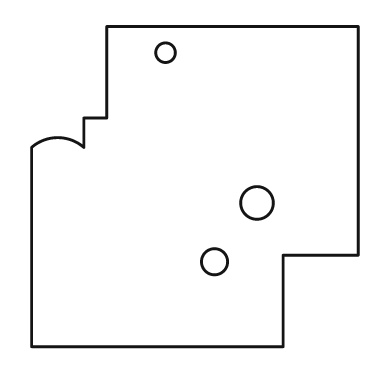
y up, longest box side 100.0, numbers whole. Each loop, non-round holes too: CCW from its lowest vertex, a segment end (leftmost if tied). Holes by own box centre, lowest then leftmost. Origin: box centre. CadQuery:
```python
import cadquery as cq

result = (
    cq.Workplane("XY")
    .moveTo(-50.0, -49.0)
    .lineTo(27.0, -49.0)
    .lineTo(27.0, -21.0)
    .lineTo(50.0, -21.0)
    .lineTo(50.0, 49.0)
    .lineTo(-27.0, 49.0)
    .lineTo(-27.0, 21.0)
    .lineTo(-34.0, 21.0)
    .lineTo(-34.0, 12.0)
    .threePointArc((-42.0, 15.0), (-50.0, 12.0))
    .close()
    .moveTo(6.0, -23.0)
    .circle(4.0)
    .moveTo(19.0, -5.0)
    .circle(5.0)
    .moveTo(-9.0, 41.0)
    .circle(3.0)
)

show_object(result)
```